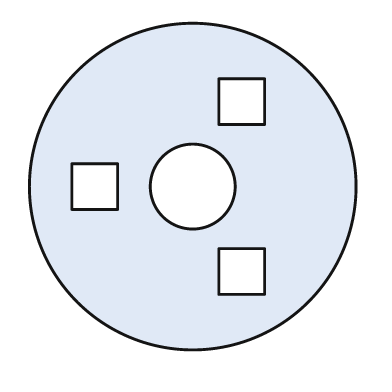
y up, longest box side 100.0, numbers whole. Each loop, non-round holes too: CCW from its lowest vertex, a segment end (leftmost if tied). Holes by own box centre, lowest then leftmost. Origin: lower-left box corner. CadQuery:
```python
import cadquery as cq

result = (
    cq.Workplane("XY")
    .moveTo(50.0, 50.0)
    .circle(50.0)
    .moveTo(58.0, 17.0)
    .lineTo(72.0, 17.0)
    .lineTo(72.0, 31.0)
    .lineTo(58.0, 31.0)
    .close()
    .moveTo(13.0, 43.0)
    .lineTo(27.0, 43.0)
    .lineTo(27.0, 57.0)
    .lineTo(13.0, 57.0)
    .close()
    .moveTo(50.0, 50.0)
    .circle(13.0)
    .moveTo(58.0, 69.0)
    .lineTo(72.0, 69.0)
    .lineTo(72.0, 83.0)
    .lineTo(58.0, 83.0)
    .close()
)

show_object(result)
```